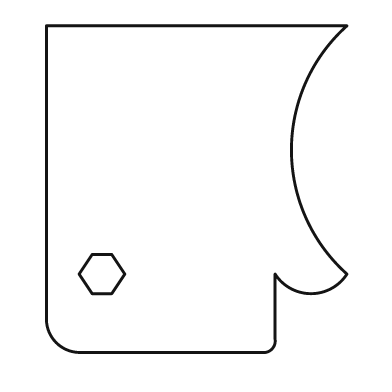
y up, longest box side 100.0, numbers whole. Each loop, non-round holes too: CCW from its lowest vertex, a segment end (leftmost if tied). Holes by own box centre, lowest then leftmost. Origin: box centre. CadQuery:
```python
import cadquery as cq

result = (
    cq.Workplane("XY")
    .moveTo(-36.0, -50.0)
    .lineTo(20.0, -50.0)
    .threePointArc((23.0, -49.0), (24.0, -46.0))
    .lineTo(24.0, -26.0)
    .threePointArc((35.0, -32.0), (46.0, -26.0))
    .threePointArc((29.0, 12.0), (46.0, 50.0))
    .lineTo(-46.0, 50.0)
    .lineTo(-46.0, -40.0)
    .threePointArc((-43.0, -47.0), (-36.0, -50.0))
    .close()
    .moveTo(-32.0, -32.0)
    .lineTo(-26.0, -32.0)
    .lineTo(-22.0, -26.0)
    .lineTo(-26.0, -20.0)
    .lineTo(-32.0, -20.0)
    .lineTo(-36.0, -26.0)
    .close()
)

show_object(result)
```